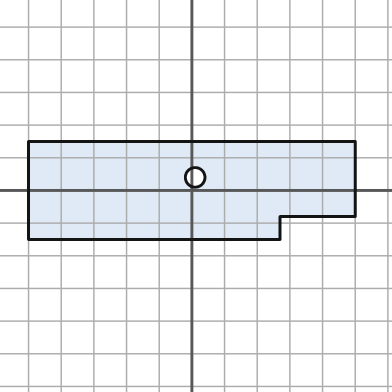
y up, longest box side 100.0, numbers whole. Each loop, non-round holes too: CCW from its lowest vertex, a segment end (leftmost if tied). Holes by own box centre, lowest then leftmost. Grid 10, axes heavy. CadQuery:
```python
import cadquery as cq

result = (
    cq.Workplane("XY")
    .moveTo(-50.0, -15.0)
    .lineTo(27.0, -15.0)
    .lineTo(27.0, -8.0)
    .lineTo(50.0, -8.0)
    .lineTo(50.0, 15.0)
    .lineTo(-50.0, 15.0)
    .close()
    .moveTo(1.0, 4.0)
    .circle(3.0)
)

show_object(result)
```